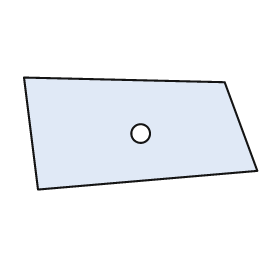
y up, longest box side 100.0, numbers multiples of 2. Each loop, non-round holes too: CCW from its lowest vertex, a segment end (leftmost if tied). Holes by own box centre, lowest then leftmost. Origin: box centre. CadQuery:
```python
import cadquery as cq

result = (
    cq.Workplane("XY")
    .moveTo(-44.0, -24.0)
    .lineTo(50.0, -16.0)
    .lineTo(36.0, 22.0)
    .lineTo(-50.0, 24.0)
    .close()
    .moveTo(0.0, 0.0)
    .circle(4.0)
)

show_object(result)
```